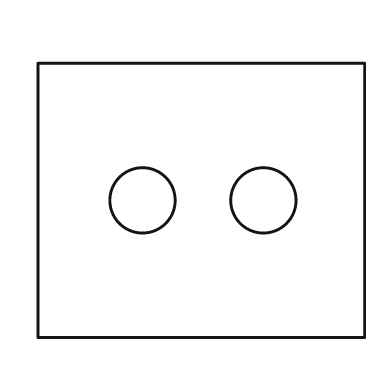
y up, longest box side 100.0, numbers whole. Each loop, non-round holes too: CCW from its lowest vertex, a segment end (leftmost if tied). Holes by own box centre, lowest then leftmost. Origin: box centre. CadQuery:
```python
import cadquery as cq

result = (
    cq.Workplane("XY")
    .moveTo(-50.0, -42.0)
    .lineTo(50.0, -42.0)
    .lineTo(50.0, 42.0)
    .lineTo(-50.0, 42.0)
    .close()
    .moveTo(-18.0, 0.0)
    .circle(10.0)
    .moveTo(19.0, 0.0)
    .circle(10.0)
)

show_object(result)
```